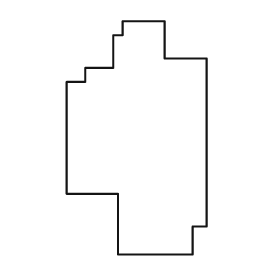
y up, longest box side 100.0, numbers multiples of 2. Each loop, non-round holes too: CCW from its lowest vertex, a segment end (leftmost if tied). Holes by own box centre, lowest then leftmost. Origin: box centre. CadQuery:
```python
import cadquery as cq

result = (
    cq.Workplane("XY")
    .moveTo(-8.0, -50.0)
    .lineTo(24.0, -50.0)
    .lineTo(24.0, -38.0)
    .lineTo(30.0, -38.0)
    .lineTo(30.0, 34.0)
    .lineTo(12.0, 34.0)
    .lineTo(12.0, 50.0)
    .lineTo(-6.0, 50.0)
    .lineTo(-6.0, 44.0)
    .lineTo(-10.0, 44.0)
    .lineTo(-10.0, 30.0)
    .lineTo(-22.0, 30.0)
    .lineTo(-22.0, 24.0)
    .lineTo(-30.0, 24.0)
    .lineTo(-30.0, -24.0)
    .lineTo(-8.0, -24.0)
    .close()
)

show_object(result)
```